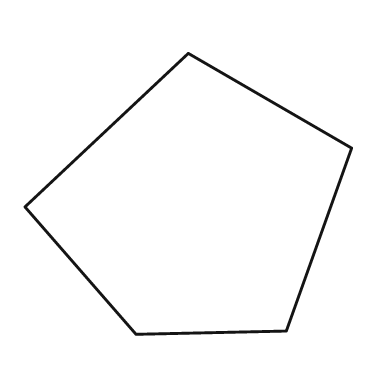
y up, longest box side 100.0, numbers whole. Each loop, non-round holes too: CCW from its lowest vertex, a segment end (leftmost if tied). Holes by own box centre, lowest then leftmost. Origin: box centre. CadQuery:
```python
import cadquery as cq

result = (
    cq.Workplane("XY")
    .moveTo(-16.0, -43.0)
    .lineTo(30.0, -42.0)
    .lineTo(50.0, 14.0)
    .lineTo(0.0, 43.0)
    .lineTo(-50.0, -4.0)
    .close()
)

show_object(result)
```